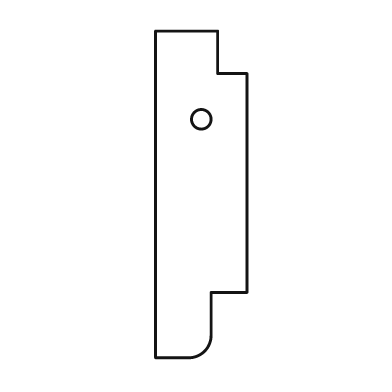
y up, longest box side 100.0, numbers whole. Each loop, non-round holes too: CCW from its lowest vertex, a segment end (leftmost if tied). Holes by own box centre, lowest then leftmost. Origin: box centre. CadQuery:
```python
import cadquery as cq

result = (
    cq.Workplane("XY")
    .moveTo(-14.0, -50.0)
    .lineTo(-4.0, -50.0)
    .threePointArc((1.0, -48.0), (3.0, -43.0))
    .lineTo(3.0, -30.0)
    .lineTo(14.0, -30.0)
    .lineTo(14.0, 37.0)
    .lineTo(5.0, 37.0)
    .lineTo(5.0, 50.0)
    .lineTo(-14.0, 50.0)
    .close()
    .moveTo(0.0, 23.0)
    .circle(3.0)
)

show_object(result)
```